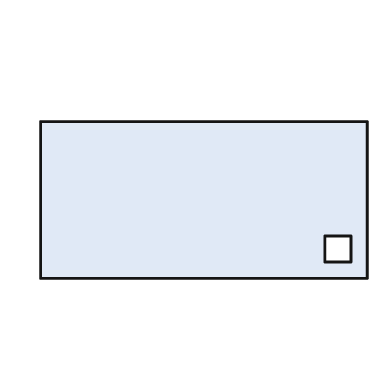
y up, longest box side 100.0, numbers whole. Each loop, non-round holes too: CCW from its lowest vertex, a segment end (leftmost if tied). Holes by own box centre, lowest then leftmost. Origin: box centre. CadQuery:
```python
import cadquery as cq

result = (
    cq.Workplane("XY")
    .moveTo(-50.0, -24.0)
    .lineTo(50.0, -24.0)
    .lineTo(50.0, 24.0)
    .lineTo(-50.0, 24.0)
    .close()
    .moveTo(37.0, -19.0)
    .lineTo(45.0, -19.0)
    .lineTo(45.0, -11.0)
    .lineTo(37.0, -11.0)
    .close()
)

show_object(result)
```